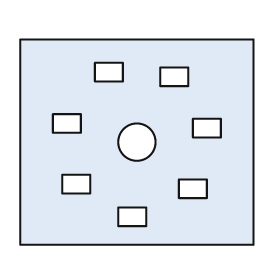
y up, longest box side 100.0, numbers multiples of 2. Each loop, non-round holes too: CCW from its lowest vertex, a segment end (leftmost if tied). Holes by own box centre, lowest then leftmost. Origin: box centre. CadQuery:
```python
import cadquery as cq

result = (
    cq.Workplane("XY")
    .moveTo(-50.0, -44.0)
    .lineTo(50.0, -44.0)
    .lineTo(50.0, 44.0)
    .lineTo(-50.0, 44.0)
    .close()
    .moveTo(-8.0, -36.0)
    .lineTo(4.0, -36.0)
    .lineTo(4.0, -28.0)
    .lineTo(-8.0, -28.0)
    .close()
    .moveTo(18.0, -24.0)
    .lineTo(30.0, -24.0)
    .lineTo(30.0, -16.0)
    .lineTo(18.0, -16.0)
    .close()
    .moveTo(-32.0, -22.0)
    .lineTo(-20.0, -22.0)
    .lineTo(-20.0, -14.0)
    .lineTo(-32.0, -14.0)
    .close()
    .moveTo(0.0, 0.0)
    .circle(8.0)
    .moveTo(24.0, 2.0)
    .lineTo(36.0, 2.0)
    .lineTo(36.0, 10.0)
    .lineTo(24.0, 10.0)
    .close()
    .moveTo(-36.0, 4.0)
    .lineTo(-24.0, 4.0)
    .lineTo(-24.0, 12.0)
    .lineTo(-36.0, 12.0)
    .close()
    .moveTo(10.0, 24.0)
    .lineTo(22.0, 24.0)
    .lineTo(22.0, 32.0)
    .lineTo(10.0, 32.0)
    .close()
    .moveTo(-18.0, 26.0)
    .lineTo(-6.0, 26.0)
    .lineTo(-6.0, 34.0)
    .lineTo(-18.0, 34.0)
    .close()
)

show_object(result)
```